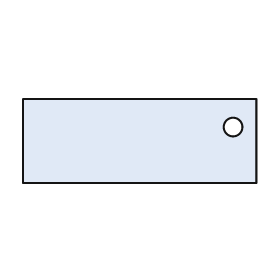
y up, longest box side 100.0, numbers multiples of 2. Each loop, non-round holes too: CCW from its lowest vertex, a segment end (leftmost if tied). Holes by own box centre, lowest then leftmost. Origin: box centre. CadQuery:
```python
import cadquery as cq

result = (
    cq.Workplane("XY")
    .moveTo(-50.0, -18.0)
    .lineTo(50.0, -18.0)
    .lineTo(50.0, 18.0)
    .lineTo(-50.0, 18.0)
    .close()
    .moveTo(40.0, 6.0)
    .circle(4.0)
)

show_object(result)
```